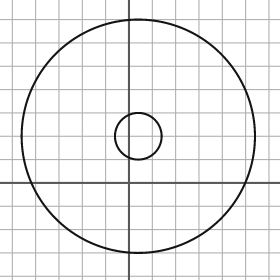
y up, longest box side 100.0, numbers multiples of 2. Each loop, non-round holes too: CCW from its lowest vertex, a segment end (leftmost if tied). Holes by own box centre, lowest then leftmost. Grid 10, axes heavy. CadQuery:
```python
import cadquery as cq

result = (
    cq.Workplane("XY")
    .moveTo(4.0, 20.0)
    .circle(50.0)
    .moveTo(4.0, 20.0)
    .circle(10.0)
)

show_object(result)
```